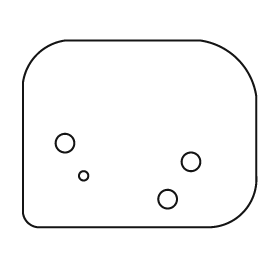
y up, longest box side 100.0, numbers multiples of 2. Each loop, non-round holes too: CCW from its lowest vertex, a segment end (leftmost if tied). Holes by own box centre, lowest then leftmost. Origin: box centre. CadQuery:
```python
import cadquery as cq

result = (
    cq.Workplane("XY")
    .moveTo(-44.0, -40.0)
    .lineTo(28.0, -40.0)
    .threePointArc((44.0, -34.0), (50.0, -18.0))
    .lineTo(50.0, 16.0)
    .threePointArc((42.0, 32.0), (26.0, 40.0))
    .lineTo(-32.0, 40.0)
    .threePointArc((-44.0, 34.0), (-50.0, 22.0))
    .lineTo(-50.0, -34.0)
    .threePointArc((-48.0, -38.0), (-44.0, -40.0))
    .close()
    .moveTo(12.0, -28.0)
    .circle(4.0)
    .moveTo(-24.0, -18.0)
    .circle(2.0)
    .moveTo(22.0, -12.0)
    .circle(4.0)
    .moveTo(-32.0, -4.0)
    .circle(4.0)
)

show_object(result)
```